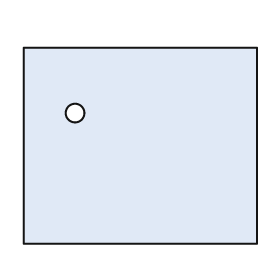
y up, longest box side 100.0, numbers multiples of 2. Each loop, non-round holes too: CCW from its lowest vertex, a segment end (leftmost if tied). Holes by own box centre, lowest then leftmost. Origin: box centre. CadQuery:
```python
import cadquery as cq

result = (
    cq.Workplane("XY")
    .moveTo(-50.0, -42.0)
    .lineTo(50.0, -42.0)
    .lineTo(50.0, 42.0)
    .lineTo(-50.0, 42.0)
    .close()
    .moveTo(-28.0, 14.0)
    .circle(4.0)
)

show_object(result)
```